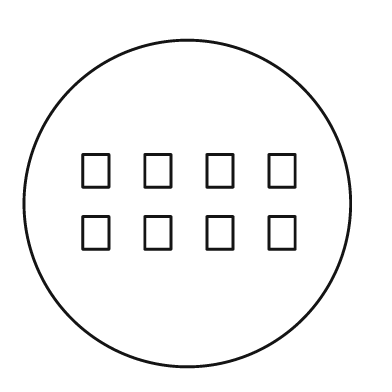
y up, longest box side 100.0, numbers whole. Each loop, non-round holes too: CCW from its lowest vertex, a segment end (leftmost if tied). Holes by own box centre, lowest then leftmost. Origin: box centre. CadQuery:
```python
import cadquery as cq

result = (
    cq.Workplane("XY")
    .moveTo(0.0, 0.0)
    .circle(50.0)
    .moveTo(-32.0, -14.0)
    .lineTo(-24.0, -14.0)
    .lineTo(-24.0, -4.0)
    .lineTo(-32.0, -4.0)
    .close()
    .moveTo(-13.0, -14.0)
    .lineTo(-5.0, -14.0)
    .lineTo(-5.0, -4.0)
    .lineTo(-13.0, -4.0)
    .close()
    .moveTo(6.0, -14.0)
    .lineTo(14.0, -14.0)
    .lineTo(14.0, -4.0)
    .lineTo(6.0, -4.0)
    .close()
    .moveTo(25.0, -14.0)
    .lineTo(33.0, -14.0)
    .lineTo(33.0, -4.0)
    .lineTo(25.0, -4.0)
    .close()
    .moveTo(-32.0, 5.0)
    .lineTo(-24.0, 5.0)
    .lineTo(-24.0, 15.0)
    .lineTo(-32.0, 15.0)
    .close()
    .moveTo(-13.0, 5.0)
    .lineTo(-5.0, 5.0)
    .lineTo(-5.0, 15.0)
    .lineTo(-13.0, 15.0)
    .close()
    .moveTo(6.0, 5.0)
    .lineTo(14.0, 5.0)
    .lineTo(14.0, 15.0)
    .lineTo(6.0, 15.0)
    .close()
    .moveTo(25.0, 5.0)
    .lineTo(33.0, 5.0)
    .lineTo(33.0, 15.0)
    .lineTo(25.0, 15.0)
    .close()
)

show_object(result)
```